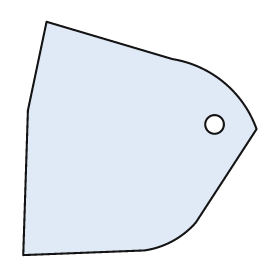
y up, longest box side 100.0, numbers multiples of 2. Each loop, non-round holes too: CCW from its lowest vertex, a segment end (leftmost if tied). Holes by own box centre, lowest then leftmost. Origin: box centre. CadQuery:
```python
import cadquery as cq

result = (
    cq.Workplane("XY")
    .moveTo(-50.0, -50.0)
    .lineTo(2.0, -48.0)
    .threePointArc((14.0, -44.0), (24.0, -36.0))
    .lineTo(50.0, 4.0)
    .threePointArc((36.0, 24.0), (14.0, 34.0))
    .lineTo(-40.0, 50.0)
    .lineTo(-48.0, 12.0)
    .close()
    .moveTo(32.0, 6.0)
    .circle(4.0)
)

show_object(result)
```